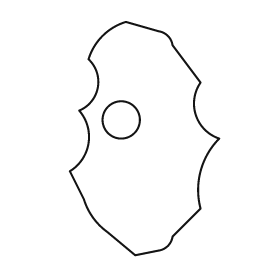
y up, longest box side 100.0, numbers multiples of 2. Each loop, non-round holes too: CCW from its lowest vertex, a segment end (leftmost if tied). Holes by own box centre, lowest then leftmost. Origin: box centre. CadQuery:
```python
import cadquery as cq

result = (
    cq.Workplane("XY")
    .moveTo(-4.0, -50.0)
    .lineTo(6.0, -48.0)
    .threePointArc((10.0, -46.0), (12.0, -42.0))
    .lineTo(24.0, -30.0)
    .threePointArc((24.0, -14.0), (32.0, 0.0))
    .threePointArc((22.0, 10.0), (24.0, 24.0))
    .lineTo(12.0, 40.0)
    .threePointArc((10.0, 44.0), (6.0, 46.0))
    .lineTo(-8.0, 50.0)
    .threePointArc((-18.0, 44.0), (-24.0, 34.0))
    .threePointArc((-20.0, 22.0), (-28.0, 12.0))
    .threePointArc((-24.0, -2.0), (-32.0, -14.0))
    .lineTo(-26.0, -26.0)
    .threePointArc((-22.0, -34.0), (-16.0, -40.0))
    .close()
    .moveTo(-10.0, 8.0)
    .circle(8.0)
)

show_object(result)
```